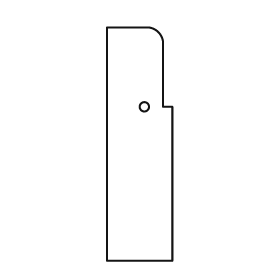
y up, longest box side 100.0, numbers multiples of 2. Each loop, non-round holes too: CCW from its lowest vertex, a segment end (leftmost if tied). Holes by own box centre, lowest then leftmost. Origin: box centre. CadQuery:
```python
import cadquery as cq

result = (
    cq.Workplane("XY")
    .moveTo(-14.0, -50.0)
    .lineTo(14.0, -50.0)
    .lineTo(14.0, 16.0)
    .lineTo(10.0, 16.0)
    .lineTo(10.0, 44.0)
    .threePointArc((8.0, 48.0), (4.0, 50.0))
    .lineTo(-14.0, 50.0)
    .close()
    .moveTo(2.0, 16.0)
    .circle(2.0)
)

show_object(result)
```